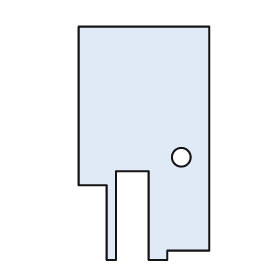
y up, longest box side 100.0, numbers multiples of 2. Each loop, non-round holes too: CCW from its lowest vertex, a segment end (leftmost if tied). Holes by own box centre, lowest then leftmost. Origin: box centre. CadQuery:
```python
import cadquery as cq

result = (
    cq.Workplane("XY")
    .moveTo(-16.0, -50.0)
    .lineTo(-12.0, -50.0)
    .lineTo(-12.0, -12.0)
    .lineTo(2.0, -12.0)
    .lineTo(2.0, -50.0)
    .lineTo(10.0, -50.0)
    .lineTo(10.0, -46.0)
    .lineTo(28.0, -46.0)
    .lineTo(28.0, 50.0)
    .lineTo(-28.0, 50.0)
    .lineTo(-28.0, -18.0)
    .lineTo(-16.0, -18.0)
    .close()
    .moveTo(16.0, -6.0)
    .circle(4.0)
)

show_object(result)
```